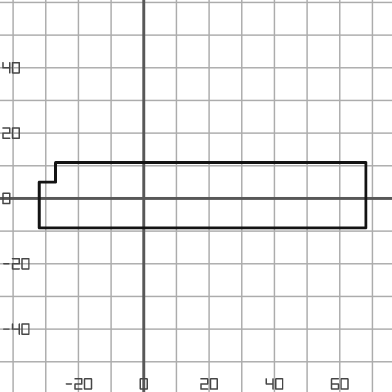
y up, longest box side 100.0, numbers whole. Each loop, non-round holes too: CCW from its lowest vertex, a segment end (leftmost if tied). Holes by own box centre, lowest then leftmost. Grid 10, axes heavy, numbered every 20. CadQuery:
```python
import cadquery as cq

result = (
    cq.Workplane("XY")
    .moveTo(-32.0, -9.0)
    .lineTo(68.0, -9.0)
    .lineTo(68.0, 11.0)
    .lineTo(-27.0, 11.0)
    .lineTo(-27.0, 5.0)
    .lineTo(-32.0, 5.0)
    .close()
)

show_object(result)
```